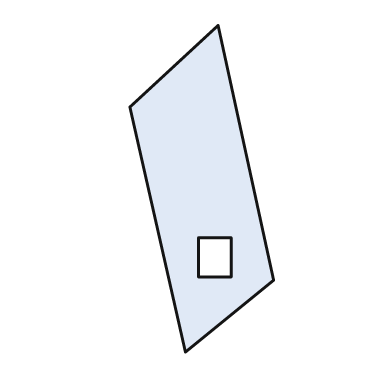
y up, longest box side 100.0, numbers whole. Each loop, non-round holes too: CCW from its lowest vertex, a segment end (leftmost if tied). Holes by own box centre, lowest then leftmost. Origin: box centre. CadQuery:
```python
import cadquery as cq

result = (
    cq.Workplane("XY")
    .moveTo(-5.0, -50.0)
    .lineTo(22.0, -28.0)
    .lineTo(5.0, 50.0)
    .lineTo(-22.0, 25.0)
    .close()
    .moveTo(-1.0, -27.0)
    .lineTo(9.0, -27.0)
    .lineTo(9.0, -15.0)
    .lineTo(-1.0, -15.0)
    .close()
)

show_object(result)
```